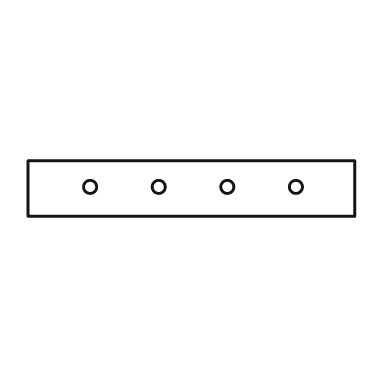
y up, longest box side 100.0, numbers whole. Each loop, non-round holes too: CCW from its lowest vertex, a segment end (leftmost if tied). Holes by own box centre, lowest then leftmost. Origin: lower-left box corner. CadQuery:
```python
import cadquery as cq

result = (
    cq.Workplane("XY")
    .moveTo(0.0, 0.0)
    .lineTo(100.0, 0.0)
    .lineTo(100.0, 17.0)
    .lineTo(0.0, 17.0)
    .close()
    .moveTo(19.0, 9.0)
    .circle(2.0)
    .moveTo(40.0, 9.0)
    .circle(2.0)
    .moveTo(61.0, 9.0)
    .circle(2.0)
    .moveTo(82.0, 9.0)
    .circle(2.0)
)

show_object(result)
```